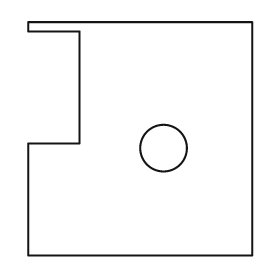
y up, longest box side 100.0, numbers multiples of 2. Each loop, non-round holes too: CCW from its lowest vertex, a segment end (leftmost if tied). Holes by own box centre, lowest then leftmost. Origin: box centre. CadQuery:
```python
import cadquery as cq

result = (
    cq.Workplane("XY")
    .moveTo(-48.0, -50.0)
    .lineTo(48.0, -50.0)
    .lineTo(48.0, 50.0)
    .lineTo(-48.0, 50.0)
    .lineTo(-48.0, 46.0)
    .lineTo(-26.0, 46.0)
    .lineTo(-26.0, -2.0)
    .lineTo(-48.0, -2.0)
    .close()
    .moveTo(10.0, -4.0)
    .circle(10.0)
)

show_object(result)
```